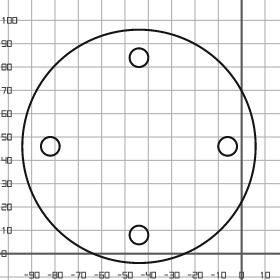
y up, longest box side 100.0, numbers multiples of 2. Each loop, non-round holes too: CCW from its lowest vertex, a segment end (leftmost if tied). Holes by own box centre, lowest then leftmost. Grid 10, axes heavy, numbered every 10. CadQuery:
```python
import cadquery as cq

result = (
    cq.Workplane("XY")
    .moveTo(-44.0, 46.0)
    .circle(50.0)
    .moveTo(-44.0, 8.0)
    .circle(4.0)
    .moveTo(-82.0, 46.0)
    .circle(4.0)
    .moveTo(-6.0, 46.0)
    .circle(4.0)
    .moveTo(-44.0, 84.0)
    .circle(4.0)
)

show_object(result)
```